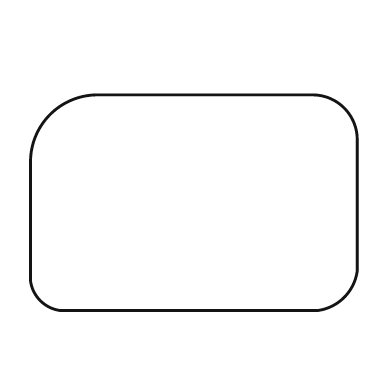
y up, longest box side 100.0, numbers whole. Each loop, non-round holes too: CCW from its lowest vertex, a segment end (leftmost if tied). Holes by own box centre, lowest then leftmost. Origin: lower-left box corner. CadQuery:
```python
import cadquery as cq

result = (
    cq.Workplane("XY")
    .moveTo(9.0, 0.0)
    .lineTo(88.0, 0.0)
    .threePointArc((96.0, 4.0), (100.0, 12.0))
    .lineTo(100.0, 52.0)
    .threePointArc((96.0, 62.0), (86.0, 66.0))
    .lineTo(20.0, 66.0)
    .threePointArc((6.0, 60.0), (0.0, 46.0))
    .lineTo(0.0, 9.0)
    .threePointArc((3.0, 3.0), (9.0, 0.0))
    .close()
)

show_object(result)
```